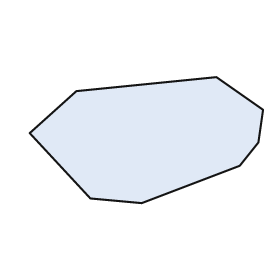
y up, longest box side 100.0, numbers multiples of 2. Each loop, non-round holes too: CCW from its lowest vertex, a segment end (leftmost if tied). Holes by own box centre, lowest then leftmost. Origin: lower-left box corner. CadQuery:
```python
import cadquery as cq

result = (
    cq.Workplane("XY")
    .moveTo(48.0, 0.0)
    .lineTo(90.0, 16.0)
    .lineTo(98.0, 26.0)
    .lineTo(100.0, 40.0)
    .lineTo(80.0, 54.0)
    .lineTo(20.0, 48.0)
    .lineTo(0.0, 30.0)
    .lineTo(26.0, 2.0)
    .close()
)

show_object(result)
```